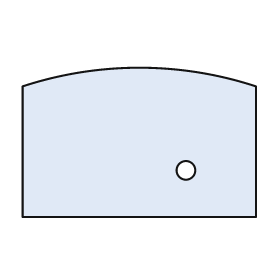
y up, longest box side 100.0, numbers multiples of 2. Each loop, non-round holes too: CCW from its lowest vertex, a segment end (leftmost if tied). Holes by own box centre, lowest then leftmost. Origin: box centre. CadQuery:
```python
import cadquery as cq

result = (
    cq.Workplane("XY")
    .moveTo(-50.0, -32.0)
    .lineTo(50.0, -32.0)
    .lineTo(50.0, 24.0)
    .threePointArc((0.0, 32.0), (-50.0, 24.0))
    .close()
    .moveTo(20.0, -12.0)
    .circle(4.0)
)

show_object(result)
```